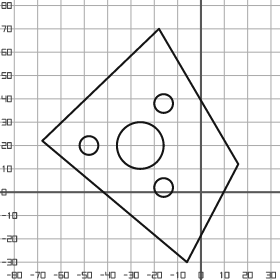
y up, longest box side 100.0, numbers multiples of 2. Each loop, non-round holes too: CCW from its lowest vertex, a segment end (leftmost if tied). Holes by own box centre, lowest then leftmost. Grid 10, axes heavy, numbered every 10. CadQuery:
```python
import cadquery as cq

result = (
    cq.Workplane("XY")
    .moveTo(-6.0, -30.0)
    .lineTo(16.0, 12.0)
    .lineTo(-18.0, 70.0)
    .lineTo(-68.0, 22.0)
    .close()
    .moveTo(-16.0, 2.0)
    .circle(4.0)
    .moveTo(-48.0, 20.0)
    .circle(4.0)
    .moveTo(-26.0, 20.0)
    .circle(10.0)
    .moveTo(-16.0, 38.0)
    .circle(4.0)
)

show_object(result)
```